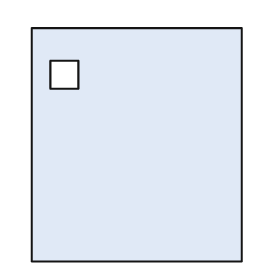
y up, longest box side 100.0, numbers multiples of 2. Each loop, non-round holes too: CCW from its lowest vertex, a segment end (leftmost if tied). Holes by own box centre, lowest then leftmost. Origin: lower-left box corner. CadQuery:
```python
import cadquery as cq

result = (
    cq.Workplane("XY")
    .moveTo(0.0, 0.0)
    .lineTo(90.0, 0.0)
    .lineTo(90.0, 100.0)
    .lineTo(0.0, 100.0)
    .close()
    .moveTo(8.0, 74.0)
    .lineTo(20.0, 74.0)
    .lineTo(20.0, 86.0)
    .lineTo(8.0, 86.0)
    .close()
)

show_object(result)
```